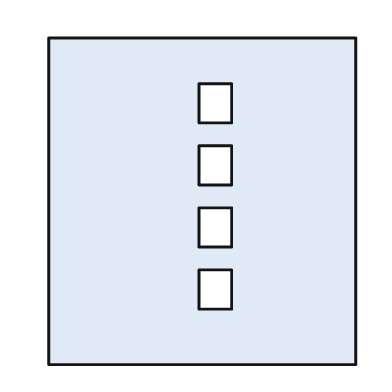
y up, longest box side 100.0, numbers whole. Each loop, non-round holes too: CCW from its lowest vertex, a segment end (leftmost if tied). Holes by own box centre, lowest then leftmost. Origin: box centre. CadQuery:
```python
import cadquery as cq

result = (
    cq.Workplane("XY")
    .moveTo(-47.0, -50.0)
    .lineTo(47.0, -50.0)
    .lineTo(47.0, 50.0)
    .lineTo(-47.0, 50.0)
    .close()
    .moveTo(-1.0, -33.0)
    .lineTo(9.0, -33.0)
    .lineTo(9.0, -21.0)
    .lineTo(-1.0, -21.0)
    .close()
    .moveTo(-1.0, -14.0)
    .lineTo(9.0, -14.0)
    .lineTo(9.0, -2.0)
    .lineTo(-1.0, -2.0)
    .close()
    .moveTo(-1.0, 5.0)
    .lineTo(9.0, 5.0)
    .lineTo(9.0, 17.0)
    .lineTo(-1.0, 17.0)
    .close()
    .moveTo(-1.0, 24.0)
    .lineTo(9.0, 24.0)
    .lineTo(9.0, 36.0)
    .lineTo(-1.0, 36.0)
    .close()
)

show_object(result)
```